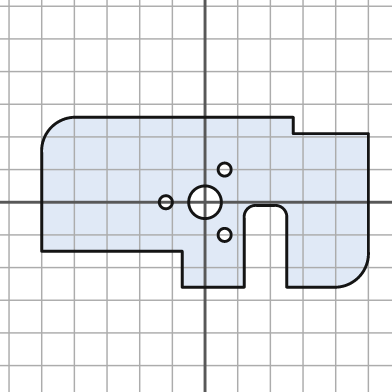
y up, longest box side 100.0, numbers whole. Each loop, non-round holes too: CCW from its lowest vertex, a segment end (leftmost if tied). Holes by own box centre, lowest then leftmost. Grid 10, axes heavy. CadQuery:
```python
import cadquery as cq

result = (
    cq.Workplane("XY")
    .moveTo(-7.0, -26.0)
    .lineTo(12.0, -26.0)
    .lineTo(12.0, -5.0)
    .threePointArc((13.0, -2.0), (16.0, -1.0))
    .lineTo(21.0, -1.0)
    .threePointArc((24.0, -2.0), (25.0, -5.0))
    .lineTo(25.0, -26.0)
    .lineTo(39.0, -26.0)
    .threePointArc((47.0, -23.0), (50.0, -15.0))
    .lineTo(50.0, 21.0)
    .lineTo(27.0, 21.0)
    .lineTo(27.0, 26.0)
    .lineTo(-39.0, 26.0)
    .threePointArc((-47.0, 23.0), (-50.0, 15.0))
    .lineTo(-50.0, -15.0)
    .lineTo(-7.0, -15.0)
    .close()
    .moveTo(6.0, -10.0)
    .circle(2.0)
    .moveTo(-12.0, 0.0)
    .circle(2.0)
    .moveTo(0.0, 0.0)
    .circle(5.0)
    .moveTo(6.0, 10.0)
    .circle(2.0)
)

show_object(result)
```